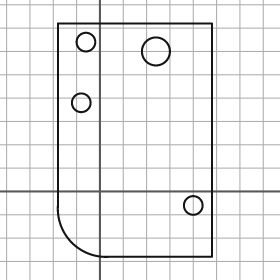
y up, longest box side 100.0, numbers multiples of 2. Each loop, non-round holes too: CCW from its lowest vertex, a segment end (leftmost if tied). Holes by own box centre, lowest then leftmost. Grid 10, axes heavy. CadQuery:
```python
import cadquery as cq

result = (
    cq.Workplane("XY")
    .moveTo(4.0, -28.0)
    .lineTo(48.0, -28.0)
    .lineTo(48.0, 72.0)
    .lineTo(-18.0, 72.0)
    .lineTo(-18.0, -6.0)
    .threePointArc((-12.0, -22.0), (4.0, -28.0))
    .close()
    .moveTo(40.0, -6.0)
    .circle(4.0)
    .moveTo(-8.0, 38.0)
    .circle(4.0)
    .moveTo(24.0, 60.0)
    .circle(6.0)
    .moveTo(-6.0, 64.0)
    .circle(4.0)
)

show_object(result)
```